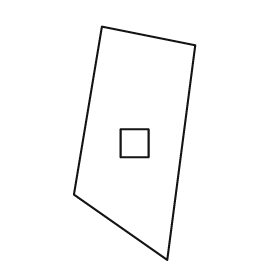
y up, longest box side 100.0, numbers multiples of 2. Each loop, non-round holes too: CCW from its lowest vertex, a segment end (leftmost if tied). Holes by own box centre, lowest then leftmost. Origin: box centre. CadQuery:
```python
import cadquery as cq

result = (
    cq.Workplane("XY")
    .moveTo(14.0, -50.0)
    .lineTo(26.0, 42.0)
    .lineTo(-14.0, 50.0)
    .lineTo(-26.0, -22.0)
    .close()
    .moveTo(-6.0, -6.0)
    .lineTo(6.0, -6.0)
    .lineTo(6.0, 6.0)
    .lineTo(-6.0, 6.0)
    .close()
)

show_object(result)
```